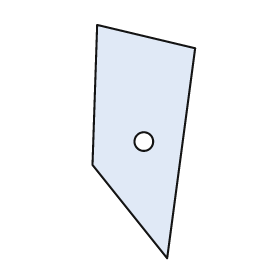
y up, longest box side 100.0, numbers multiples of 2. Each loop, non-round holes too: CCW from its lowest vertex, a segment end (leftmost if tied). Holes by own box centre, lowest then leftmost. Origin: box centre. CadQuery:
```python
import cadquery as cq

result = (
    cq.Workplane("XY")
    .moveTo(10.0, -50.0)
    .lineTo(22.0, 40.0)
    .lineTo(-20.0, 50.0)
    .lineTo(-22.0, -10.0)
    .close()
    .moveTo(0.0, 0.0)
    .circle(4.0)
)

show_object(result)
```